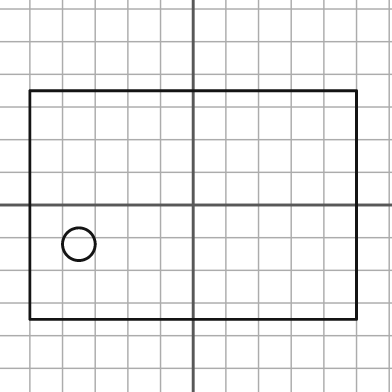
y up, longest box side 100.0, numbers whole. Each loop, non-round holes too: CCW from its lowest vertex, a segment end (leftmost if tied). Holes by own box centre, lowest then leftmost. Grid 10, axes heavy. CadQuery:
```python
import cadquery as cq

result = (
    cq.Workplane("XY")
    .moveTo(-50.0, -35.0)
    .lineTo(50.0, -35.0)
    .lineTo(50.0, 35.0)
    .lineTo(-50.0, 35.0)
    .close()
    .moveTo(-35.0, -12.0)
    .circle(5.0)
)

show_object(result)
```